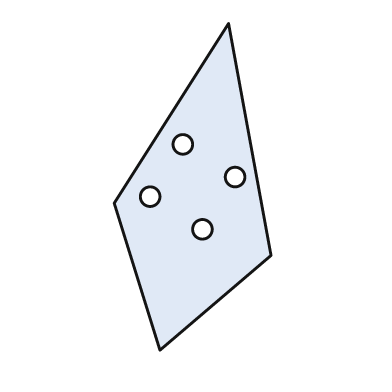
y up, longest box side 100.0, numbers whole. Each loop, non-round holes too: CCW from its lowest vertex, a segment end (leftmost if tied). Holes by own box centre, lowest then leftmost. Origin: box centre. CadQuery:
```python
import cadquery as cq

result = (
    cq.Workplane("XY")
    .moveTo(-10.0, -50.0)
    .lineTo(24.0, -21.0)
    .lineTo(11.0, 50.0)
    .lineTo(-24.0, -5.0)
    .close()
    .moveTo(3.0, -13.0)
    .circle(3.0)
    .moveTo(-13.0, -3.0)
    .circle(3.0)
    .moveTo(13.0, 3.0)
    .circle(3.0)
    .moveTo(-3.0, 13.0)
    .circle(3.0)
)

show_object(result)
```